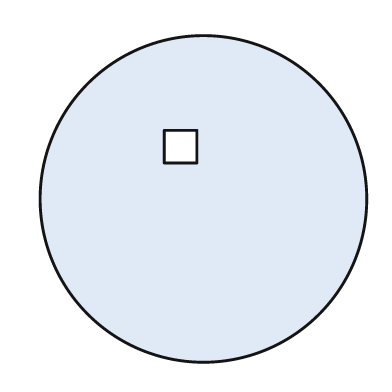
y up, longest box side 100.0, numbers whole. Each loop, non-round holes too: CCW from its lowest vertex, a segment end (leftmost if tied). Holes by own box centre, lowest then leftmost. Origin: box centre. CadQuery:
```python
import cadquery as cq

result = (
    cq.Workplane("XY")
    .moveTo(0.0, 0.0)
    .circle(50.0)
    .moveTo(-12.0, 11.0)
    .lineTo(-2.0, 11.0)
    .lineTo(-2.0, 21.0)
    .lineTo(-12.0, 21.0)
    .close()
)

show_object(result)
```